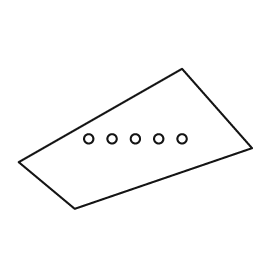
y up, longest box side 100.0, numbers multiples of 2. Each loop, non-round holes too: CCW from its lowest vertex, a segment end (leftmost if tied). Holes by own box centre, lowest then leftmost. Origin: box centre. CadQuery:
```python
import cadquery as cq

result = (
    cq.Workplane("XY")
    .moveTo(-26.0, -30.0)
    .lineTo(50.0, -4.0)
    .lineTo(20.0, 30.0)
    .lineTo(-50.0, -10.0)
    .close()
    .moveTo(-20.0, 0.0)
    .circle(2.0)
    .moveTo(-10.0, 0.0)
    .circle(2.0)
    .moveTo(0.0, 0.0)
    .circle(2.0)
    .moveTo(10.0, 0.0)
    .circle(2.0)
    .moveTo(20.0, 0.0)
    .circle(2.0)
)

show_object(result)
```